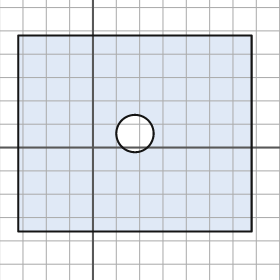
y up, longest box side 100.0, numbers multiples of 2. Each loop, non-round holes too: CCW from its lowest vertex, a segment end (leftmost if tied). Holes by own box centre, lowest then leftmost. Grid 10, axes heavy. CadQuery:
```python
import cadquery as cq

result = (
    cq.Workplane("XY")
    .moveTo(-32.0, -36.0)
    .lineTo(68.0, -36.0)
    .lineTo(68.0, 48.0)
    .lineTo(-32.0, 48.0)
    .close()
    .moveTo(18.0, 6.0)
    .circle(8.0)
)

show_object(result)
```